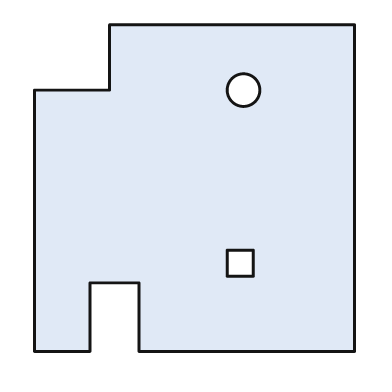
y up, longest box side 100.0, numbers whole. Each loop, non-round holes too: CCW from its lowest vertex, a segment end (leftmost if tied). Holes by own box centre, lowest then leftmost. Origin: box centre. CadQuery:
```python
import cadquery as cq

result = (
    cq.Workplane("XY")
    .moveTo(-49.0, -50.0)
    .lineTo(-32.0, -50.0)
    .lineTo(-32.0, -29.0)
    .lineTo(-17.0, -29.0)
    .lineTo(-17.0, -50.0)
    .lineTo(49.0, -50.0)
    .lineTo(49.0, 50.0)
    .lineTo(-26.0, 50.0)
    .lineTo(-26.0, 30.0)
    .lineTo(-49.0, 30.0)
    .close()
    .moveTo(10.0, -27.0)
    .lineTo(18.0, -27.0)
    .lineTo(18.0, -19.0)
    .lineTo(10.0, -19.0)
    .close()
    .moveTo(15.0, 30.0)
    .circle(5.0)
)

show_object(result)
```